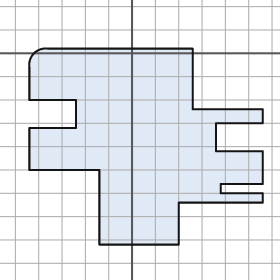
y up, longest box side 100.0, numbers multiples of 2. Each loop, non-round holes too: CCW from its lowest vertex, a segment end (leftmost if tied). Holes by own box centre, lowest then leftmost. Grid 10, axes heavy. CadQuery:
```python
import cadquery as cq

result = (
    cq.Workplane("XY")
    .moveTo(-14.0, -82.0)
    .lineTo(20.0, -82.0)
    .lineTo(20.0, -64.0)
    .lineTo(56.0, -64.0)
    .lineTo(56.0, -60.0)
    .lineTo(38.0, -60.0)
    .lineTo(38.0, -56.0)
    .lineTo(56.0, -56.0)
    .lineTo(56.0, -42.0)
    .lineTo(36.0, -42.0)
    .lineTo(36.0, -30.0)
    .lineTo(56.0, -30.0)
    .lineTo(56.0, -24.0)
    .lineTo(26.0, -24.0)
    .lineTo(26.0, 2.0)
    .lineTo(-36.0, 2.0)
    .threePointArc((-42.0, 0.0), (-44.0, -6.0))
    .lineTo(-44.0, -20.0)
    .lineTo(-24.0, -20.0)
    .lineTo(-24.0, -32.0)
    .lineTo(-44.0, -32.0)
    .lineTo(-44.0, -50.0)
    .lineTo(-14.0, -50.0)
    .close()
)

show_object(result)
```